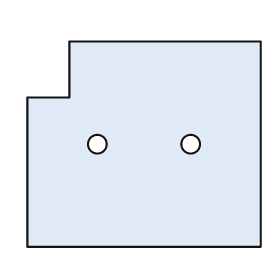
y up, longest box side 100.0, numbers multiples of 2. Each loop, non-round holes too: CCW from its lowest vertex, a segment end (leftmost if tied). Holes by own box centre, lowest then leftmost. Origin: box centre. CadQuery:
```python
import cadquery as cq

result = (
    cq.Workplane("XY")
    .moveTo(-50.0, -44.0)
    .lineTo(50.0, -44.0)
    .lineTo(50.0, 44.0)
    .lineTo(-32.0, 44.0)
    .lineTo(-32.0, 20.0)
    .lineTo(-50.0, 20.0)
    .close()
    .moveTo(-20.0, 0.0)
    .circle(4.0)
    .moveTo(20.0, 0.0)
    .circle(4.0)
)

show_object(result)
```